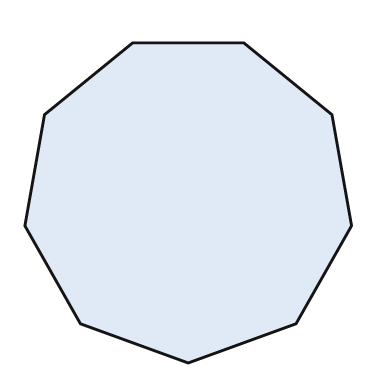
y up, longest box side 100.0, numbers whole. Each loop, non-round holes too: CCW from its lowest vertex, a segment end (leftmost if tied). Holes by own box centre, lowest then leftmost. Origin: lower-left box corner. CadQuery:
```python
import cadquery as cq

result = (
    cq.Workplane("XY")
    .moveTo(50.0, 0.0)
    .lineTo(83.0, 12.0)
    .lineTo(100.0, 42.0)
    .lineTo(94.0, 76.0)
    .lineTo(67.0, 98.0)
    .lineTo(33.0, 98.0)
    .lineTo(6.0, 76.0)
    .lineTo(0.0, 42.0)
    .lineTo(17.0, 12.0)
    .close()
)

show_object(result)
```